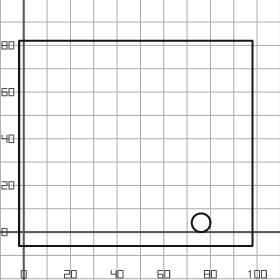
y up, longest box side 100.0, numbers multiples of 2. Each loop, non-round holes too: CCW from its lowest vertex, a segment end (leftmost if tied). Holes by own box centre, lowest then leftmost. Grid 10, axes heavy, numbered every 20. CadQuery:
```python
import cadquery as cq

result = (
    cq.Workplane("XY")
    .moveTo(-2.0, -6.0)
    .lineTo(98.0, -6.0)
    .lineTo(98.0, 82.0)
    .lineTo(-2.0, 82.0)
    .close()
    .moveTo(76.0, 4.0)
    .circle(4.0)
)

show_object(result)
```